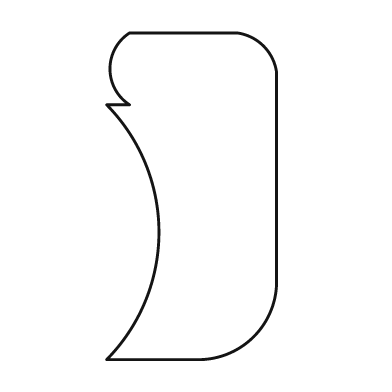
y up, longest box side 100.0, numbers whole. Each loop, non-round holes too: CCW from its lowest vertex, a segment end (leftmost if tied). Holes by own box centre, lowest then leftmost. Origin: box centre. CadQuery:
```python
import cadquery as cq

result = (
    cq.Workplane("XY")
    .moveTo(-26.0, -50.0)
    .lineTo(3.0, -50.0)
    .threePointArc((19.0, -43.0), (26.0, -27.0))
    .lineTo(26.0, 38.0)
    .threePointArc((22.0, 46.0), (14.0, 50.0))
    .lineTo(-19.0, 50.0)
    .threePointArc((-25.0, 39.0), (-19.0, 28.0))
    .lineTo(-26.0, 28.0)
    .threePointArc((-10.0, -11.0), (-26.0, -50.0))
    .close()
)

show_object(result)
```